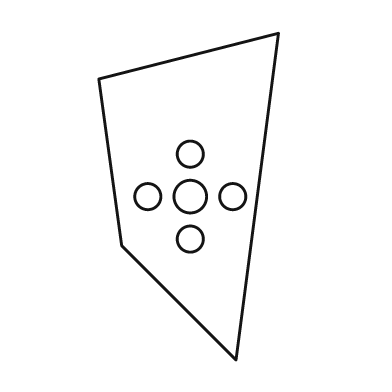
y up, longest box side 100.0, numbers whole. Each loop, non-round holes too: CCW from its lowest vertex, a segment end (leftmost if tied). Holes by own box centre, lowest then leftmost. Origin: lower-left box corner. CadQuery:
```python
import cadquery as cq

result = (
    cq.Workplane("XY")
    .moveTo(42.0, 0.0)
    .lineTo(55.0, 100.0)
    .lineTo(0.0, 86.0)
    .lineTo(7.0, 35.0)
    .close()
    .moveTo(28.0, 37.0)
    .circle(4.0)
    .moveTo(15.0, 50.0)
    .circle(4.0)
    .moveTo(28.0, 50.0)
    .circle(5.0)
    .moveTo(41.0, 50.0)
    .circle(4.0)
    .moveTo(28.0, 63.0)
    .circle(4.0)
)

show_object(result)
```